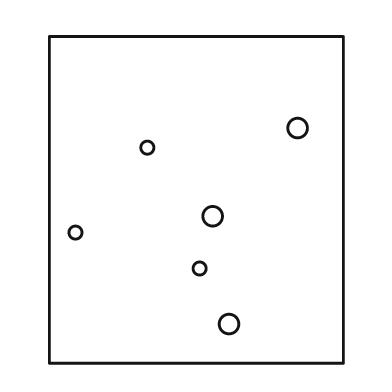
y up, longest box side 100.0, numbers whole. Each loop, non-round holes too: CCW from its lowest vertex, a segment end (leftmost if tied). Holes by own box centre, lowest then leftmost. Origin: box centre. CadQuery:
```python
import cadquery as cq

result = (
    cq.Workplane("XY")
    .moveTo(-45.0, -50.0)
    .lineTo(45.0, -50.0)
    .lineTo(45.0, 50.0)
    .lineTo(-45.0, 50.0)
    .close()
    .moveTo(10.0, -38.0)
    .circle(3.0)
    .moveTo(1.0, -21.0)
    .circle(2.0)
    .moveTo(-37.0, -10.0)
    .circle(2.0)
    .moveTo(5.0, -5.0)
    .circle(3.0)
    .moveTo(-15.0, 16.0)
    .circle(2.0)
    .moveTo(31.0, 22.0)
    .circle(3.0)
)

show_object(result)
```